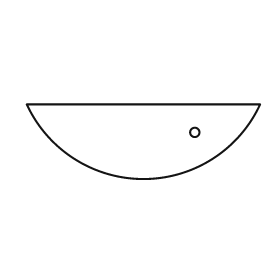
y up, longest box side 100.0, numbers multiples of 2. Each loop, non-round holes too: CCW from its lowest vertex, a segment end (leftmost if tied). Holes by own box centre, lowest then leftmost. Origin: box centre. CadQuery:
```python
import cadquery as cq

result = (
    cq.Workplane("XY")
    .moveTo(-50.0, 16.0)
    .threePointArc((0.0, -16.0), (50.0, 16.0))
    .close()
    .moveTo(22.0, 4.0)
    .circle(2.0)
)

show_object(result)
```